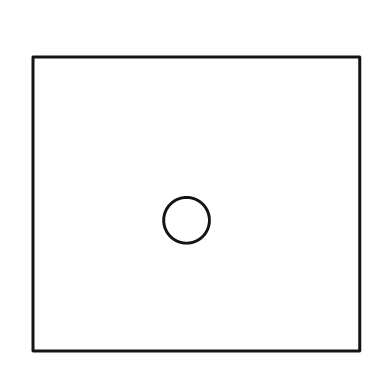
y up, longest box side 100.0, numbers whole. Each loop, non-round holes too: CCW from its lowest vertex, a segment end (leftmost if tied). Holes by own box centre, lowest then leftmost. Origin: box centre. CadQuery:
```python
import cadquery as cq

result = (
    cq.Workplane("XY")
    .moveTo(-50.0, -45.0)
    .lineTo(50.0, -45.0)
    .lineTo(50.0, 45.0)
    .lineTo(-50.0, 45.0)
    .close()
    .moveTo(-3.0, -5.0)
    .circle(7.0)
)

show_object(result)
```